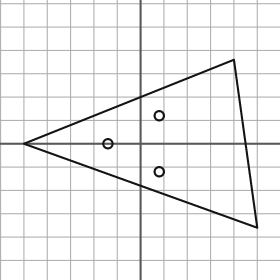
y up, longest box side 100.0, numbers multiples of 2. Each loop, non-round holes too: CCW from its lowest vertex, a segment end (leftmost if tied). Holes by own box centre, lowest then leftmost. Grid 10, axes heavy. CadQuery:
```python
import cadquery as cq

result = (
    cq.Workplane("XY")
    .moveTo(50.0, -36.0)
    .lineTo(40.0, 36.0)
    .lineTo(-50.0, 0.0)
    .close()
    .moveTo(8.0, -12.0)
    .circle(2.0)
    .moveTo(-14.0, 0.0)
    .circle(2.0)
    .moveTo(8.0, 12.0)
    .circle(2.0)
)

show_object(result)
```